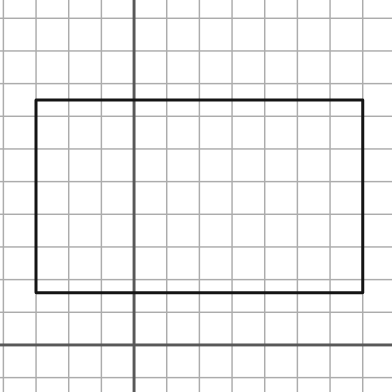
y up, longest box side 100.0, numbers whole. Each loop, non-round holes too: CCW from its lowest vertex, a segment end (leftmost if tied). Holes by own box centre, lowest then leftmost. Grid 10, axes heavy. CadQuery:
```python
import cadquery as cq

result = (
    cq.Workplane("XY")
    .moveTo(-30.0, 16.0)
    .lineTo(70.0, 16.0)
    .lineTo(70.0, 75.0)
    .lineTo(-30.0, 75.0)
    .close()
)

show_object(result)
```